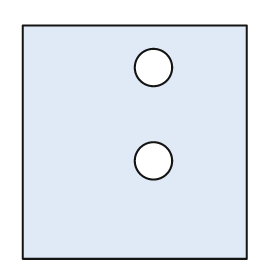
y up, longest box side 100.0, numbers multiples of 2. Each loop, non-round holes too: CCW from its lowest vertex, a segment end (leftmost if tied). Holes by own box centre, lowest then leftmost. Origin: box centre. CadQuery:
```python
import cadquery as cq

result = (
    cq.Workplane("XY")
    .moveTo(-48.0, -50.0)
    .lineTo(48.0, -50.0)
    .lineTo(48.0, 50.0)
    .lineTo(-48.0, 50.0)
    .close()
    .moveTo(8.0, -8.0)
    .circle(8.0)
    .moveTo(8.0, 32.0)
    .circle(8.0)
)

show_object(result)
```